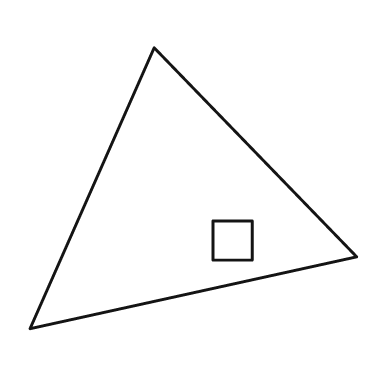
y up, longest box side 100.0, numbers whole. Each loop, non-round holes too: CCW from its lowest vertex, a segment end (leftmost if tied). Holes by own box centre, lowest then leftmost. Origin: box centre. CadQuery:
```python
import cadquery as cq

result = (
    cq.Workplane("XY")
    .moveTo(-50.0, -43.0)
    .lineTo(50.0, -21.0)
    .lineTo(-12.0, 43.0)
    .close()
    .moveTo(6.0, -22.0)
    .lineTo(18.0, -22.0)
    .lineTo(18.0, -10.0)
    .lineTo(6.0, -10.0)
    .close()
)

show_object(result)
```